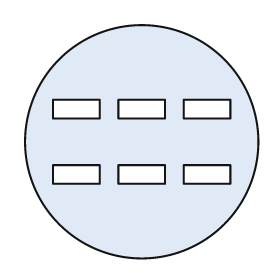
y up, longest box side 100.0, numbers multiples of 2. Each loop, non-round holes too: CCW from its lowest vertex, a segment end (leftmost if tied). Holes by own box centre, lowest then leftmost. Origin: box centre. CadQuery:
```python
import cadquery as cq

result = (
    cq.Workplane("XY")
    .moveTo(0.0, 0.0)
    .circle(50.0)
    .moveTo(-38.0, -18.0)
    .lineTo(-18.0, -18.0)
    .lineTo(-18.0, -10.0)
    .lineTo(-38.0, -10.0)
    .close()
    .moveTo(-10.0, -18.0)
    .lineTo(10.0, -18.0)
    .lineTo(10.0, -10.0)
    .lineTo(-10.0, -10.0)
    .close()
    .moveTo(18.0, -18.0)
    .lineTo(38.0, -18.0)
    .lineTo(38.0, -10.0)
    .lineTo(18.0, -10.0)
    .close()
    .moveTo(-38.0, 10.0)
    .lineTo(-18.0, 10.0)
    .lineTo(-18.0, 18.0)
    .lineTo(-38.0, 18.0)
    .close()
    .moveTo(-10.0, 10.0)
    .lineTo(10.0, 10.0)
    .lineTo(10.0, 18.0)
    .lineTo(-10.0, 18.0)
    .close()
    .moveTo(18.0, 10.0)
    .lineTo(38.0, 10.0)
    .lineTo(38.0, 18.0)
    .lineTo(18.0, 18.0)
    .close()
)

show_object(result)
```